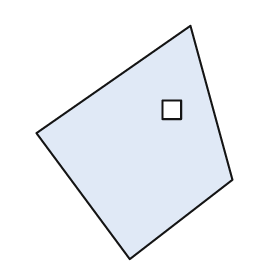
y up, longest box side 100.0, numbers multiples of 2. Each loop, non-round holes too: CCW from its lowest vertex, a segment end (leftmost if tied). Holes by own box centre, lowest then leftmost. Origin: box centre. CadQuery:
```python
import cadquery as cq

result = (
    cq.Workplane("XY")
    .moveTo(-2.0, -50.0)
    .lineTo(42.0, -16.0)
    .lineTo(24.0, 50.0)
    .lineTo(-42.0, 4.0)
    .close()
    .moveTo(12.0, 10.0)
    .lineTo(20.0, 10.0)
    .lineTo(20.0, 18.0)
    .lineTo(12.0, 18.0)
    .close()
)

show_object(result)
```